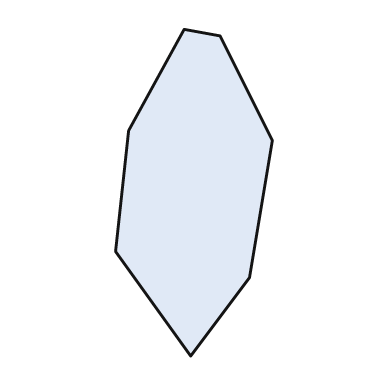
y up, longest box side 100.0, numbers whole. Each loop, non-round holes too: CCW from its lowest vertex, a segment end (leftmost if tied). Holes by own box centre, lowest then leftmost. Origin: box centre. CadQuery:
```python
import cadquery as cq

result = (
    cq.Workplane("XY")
    .moveTo(-1.0, -50.0)
    .lineTo(17.0, -26.0)
    .lineTo(24.0, 16.0)
    .lineTo(8.0, 48.0)
    .lineTo(-3.0, 50.0)
    .lineTo(-20.0, 19.0)
    .lineTo(-24.0, -18.0)
    .close()
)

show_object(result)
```